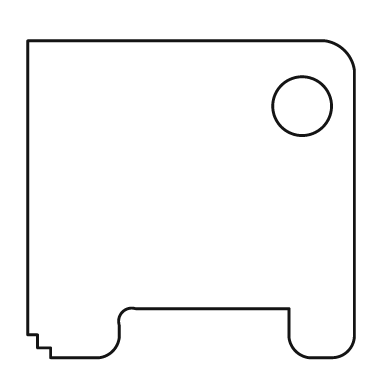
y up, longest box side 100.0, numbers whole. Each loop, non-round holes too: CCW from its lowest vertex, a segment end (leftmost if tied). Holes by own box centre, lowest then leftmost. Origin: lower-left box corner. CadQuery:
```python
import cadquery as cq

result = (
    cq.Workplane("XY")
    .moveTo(7.0, 0.0)
    .lineTo(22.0, 0.0)
    .threePointArc((26.0, 2.0), (28.0, 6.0))
    .lineTo(28.0, 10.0)
    .threePointArc((29.0, 14.0), (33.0, 15.0))
    .lineTo(80.0, 15.0)
    .lineTo(80.0, 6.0)
    .threePointArc((82.0, 2.0), (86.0, 0.0))
    .lineTo(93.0, 0.0)
    .threePointArc((98.0, 2.0), (100.0, 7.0))
    .lineTo(100.0, 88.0)
    .threePointArc((97.0, 94.0), (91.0, 97.0))
    .lineTo(0.0, 97.0)
    .lineTo(0.0, 7.0)
    .lineTo(3.0, 7.0)
    .lineTo(3.0, 3.0)
    .lineTo(7.0, 3.0)
    .close()
    .moveTo(84.0, 77.0)
    .circle(9.0)
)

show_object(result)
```